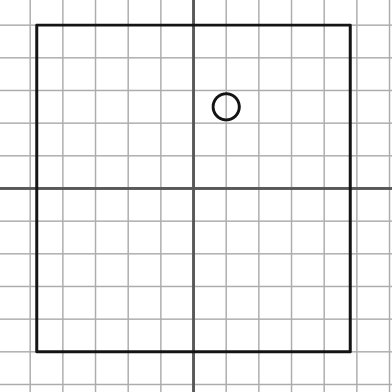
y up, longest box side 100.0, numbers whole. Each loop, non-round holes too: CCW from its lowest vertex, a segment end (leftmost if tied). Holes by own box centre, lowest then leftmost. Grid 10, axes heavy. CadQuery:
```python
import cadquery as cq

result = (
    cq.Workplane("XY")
    .moveTo(-48.0, -50.0)
    .lineTo(48.0, -50.0)
    .lineTo(48.0, 50.0)
    .lineTo(-48.0, 50.0)
    .close()
    .moveTo(10.0, 25.0)
    .circle(4.0)
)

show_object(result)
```